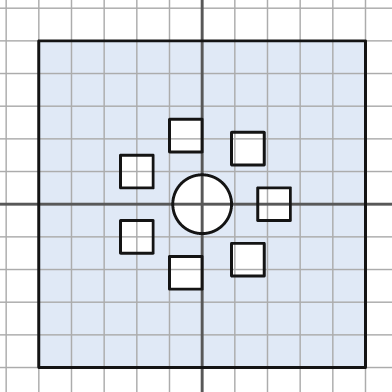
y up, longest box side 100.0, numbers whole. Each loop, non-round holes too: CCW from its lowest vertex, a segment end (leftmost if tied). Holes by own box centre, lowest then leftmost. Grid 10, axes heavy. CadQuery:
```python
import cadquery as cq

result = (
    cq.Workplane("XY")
    .moveTo(-50.0, -50.0)
    .lineTo(50.0, -50.0)
    .lineTo(50.0, 50.0)
    .lineTo(-50.0, 50.0)
    .close()
    .moveTo(-10.0, -26.0)
    .lineTo(0.0, -26.0)
    .lineTo(0.0, -16.0)
    .lineTo(-10.0, -16.0)
    .close()
    .moveTo(9.0, -22.0)
    .lineTo(19.0, -22.0)
    .lineTo(19.0, -12.0)
    .lineTo(9.0, -12.0)
    .close()
    .moveTo(-25.0, -15.0)
    .lineTo(-15.0, -15.0)
    .lineTo(-15.0, -5.0)
    .lineTo(-25.0, -5.0)
    .close()
    .moveTo(0.0, 0.0)
    .circle(9.0)
    .moveTo(17.0, -5.0)
    .lineTo(27.0, -5.0)
    .lineTo(27.0, 5.0)
    .lineTo(17.0, 5.0)
    .close()
    .moveTo(-25.0, 5.0)
    .lineTo(-15.0, 5.0)
    .lineTo(-15.0, 15.0)
    .lineTo(-25.0, 15.0)
    .close()
    .moveTo(9.0, 12.0)
    .lineTo(19.0, 12.0)
    .lineTo(19.0, 22.0)
    .lineTo(9.0, 22.0)
    .close()
    .moveTo(-10.0, 16.0)
    .lineTo(0.0, 16.0)
    .lineTo(0.0, 26.0)
    .lineTo(-10.0, 26.0)
    .close()
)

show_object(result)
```